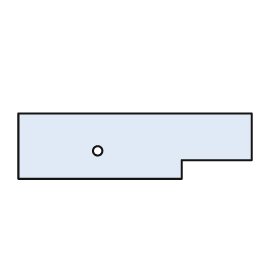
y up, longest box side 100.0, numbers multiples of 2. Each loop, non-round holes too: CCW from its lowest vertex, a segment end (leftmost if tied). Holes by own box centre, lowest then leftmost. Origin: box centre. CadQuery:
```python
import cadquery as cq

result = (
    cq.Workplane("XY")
    .moveTo(-50.0, -14.0)
    .lineTo(20.0, -14.0)
    .lineTo(20.0, -6.0)
    .lineTo(50.0, -6.0)
    .lineTo(50.0, 14.0)
    .lineTo(-50.0, 14.0)
    .close()
    .moveTo(-16.0, -2.0)
    .circle(2.0)
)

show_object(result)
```